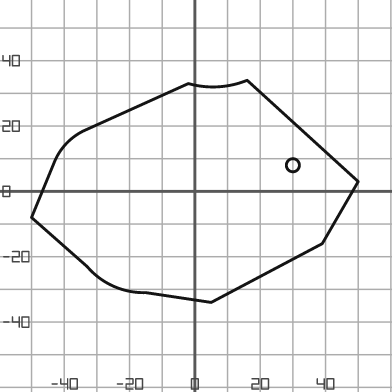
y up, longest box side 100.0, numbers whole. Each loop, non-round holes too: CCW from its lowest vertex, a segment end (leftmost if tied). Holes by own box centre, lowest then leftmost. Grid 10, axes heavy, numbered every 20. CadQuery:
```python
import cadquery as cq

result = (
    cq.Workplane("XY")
    .moveTo(5.0, -34.0)
    .lineTo(39.0, -16.0)
    .lineTo(50.0, 3.0)
    .lineTo(16.0, 34.0)
    .threePointArc((7.0, 32.0), (-2.0, 33.0))
    .lineTo(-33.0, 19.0)
    .threePointArc((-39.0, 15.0), (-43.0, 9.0))
    .lineTo(-50.0, -8.0)
    .lineTo(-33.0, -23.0)
    .threePointArc((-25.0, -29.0), (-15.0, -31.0))
    .close()
    .moveTo(30.0, 8.0)
    .circle(2.0)
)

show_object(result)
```